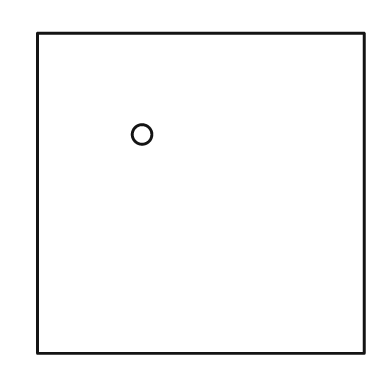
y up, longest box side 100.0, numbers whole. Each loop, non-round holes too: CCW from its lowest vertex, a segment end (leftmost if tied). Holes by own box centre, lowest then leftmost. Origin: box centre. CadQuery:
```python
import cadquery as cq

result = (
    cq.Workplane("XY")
    .moveTo(-50.0, -49.0)
    .lineTo(50.0, -49.0)
    .lineTo(50.0, 49.0)
    .lineTo(-50.0, 49.0)
    .close()
    .moveTo(-18.0, 18.0)
    .circle(3.0)
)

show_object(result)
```